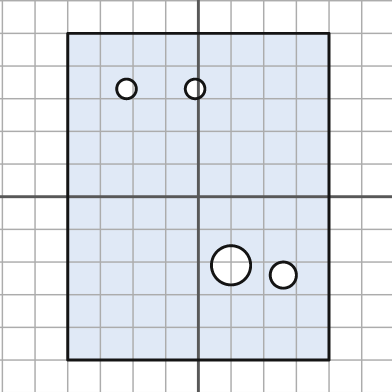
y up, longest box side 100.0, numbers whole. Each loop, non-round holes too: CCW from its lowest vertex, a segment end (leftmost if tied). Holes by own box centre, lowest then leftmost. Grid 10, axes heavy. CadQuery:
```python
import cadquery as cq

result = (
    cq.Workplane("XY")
    .moveTo(-40.0, -50.0)
    .lineTo(40.0, -50.0)
    .lineTo(40.0, 50.0)
    .lineTo(-40.0, 50.0)
    .close()
    .moveTo(26.0, -24.0)
    .circle(4.0)
    .moveTo(10.0, -21.0)
    .circle(6.0)
    .moveTo(-22.0, 33.0)
    .circle(3.0)
    .moveTo(-1.0, 33.0)
    .circle(3.0)
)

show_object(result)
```